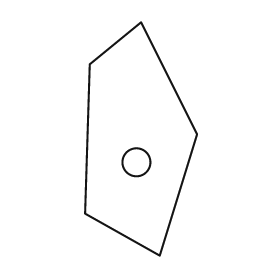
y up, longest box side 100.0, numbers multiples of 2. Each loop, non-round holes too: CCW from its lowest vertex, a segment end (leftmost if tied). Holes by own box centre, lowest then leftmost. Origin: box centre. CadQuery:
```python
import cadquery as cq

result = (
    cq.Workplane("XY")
    .moveTo(8.0, -50.0)
    .lineTo(24.0, 2.0)
    .lineTo(0.0, 50.0)
    .lineTo(-22.0, 32.0)
    .lineTo(-24.0, -32.0)
    .close()
    .moveTo(-2.0, -10.0)
    .circle(6.0)
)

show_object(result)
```